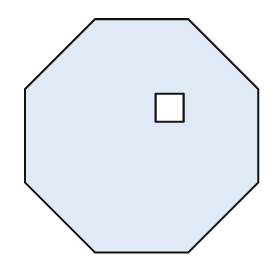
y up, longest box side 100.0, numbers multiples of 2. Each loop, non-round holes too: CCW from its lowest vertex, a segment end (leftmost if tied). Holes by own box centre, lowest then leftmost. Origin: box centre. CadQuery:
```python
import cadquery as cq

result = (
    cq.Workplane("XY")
    .moveTo(-20.0, -50.0)
    .lineTo(20.0, -50.0)
    .lineTo(50.0, -20.0)
    .lineTo(50.0, 20.0)
    .lineTo(20.0, 50.0)
    .lineTo(-20.0, 50.0)
    .lineTo(-50.0, 20.0)
    .lineTo(-50.0, -20.0)
    .close()
    .moveTo(6.0, 6.0)
    .lineTo(18.0, 6.0)
    .lineTo(18.0, 18.0)
    .lineTo(6.0, 18.0)
    .close()
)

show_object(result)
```